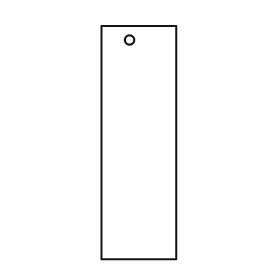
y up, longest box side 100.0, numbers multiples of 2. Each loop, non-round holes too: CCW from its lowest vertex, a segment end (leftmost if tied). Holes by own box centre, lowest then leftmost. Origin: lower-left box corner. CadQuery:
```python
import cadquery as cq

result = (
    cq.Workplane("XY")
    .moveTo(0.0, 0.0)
    .lineTo(32.0, 0.0)
    .lineTo(32.0, 100.0)
    .lineTo(0.0, 100.0)
    .close()
    .moveTo(12.0, 94.0)
    .circle(2.0)
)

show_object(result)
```